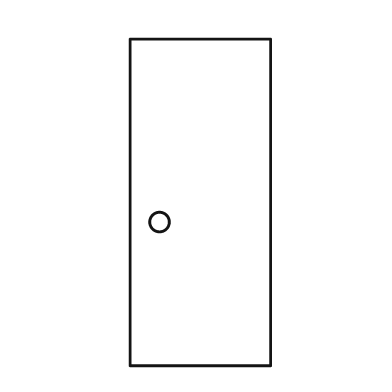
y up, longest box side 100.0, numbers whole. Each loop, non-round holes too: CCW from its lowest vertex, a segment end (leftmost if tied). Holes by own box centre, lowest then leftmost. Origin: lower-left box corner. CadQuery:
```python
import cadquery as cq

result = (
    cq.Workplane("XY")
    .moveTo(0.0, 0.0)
    .lineTo(43.0, 0.0)
    .lineTo(43.0, 100.0)
    .lineTo(0.0, 100.0)
    .close()
    .moveTo(9.0, 44.0)
    .circle(3.0)
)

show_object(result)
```